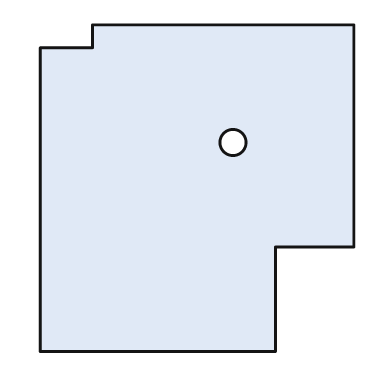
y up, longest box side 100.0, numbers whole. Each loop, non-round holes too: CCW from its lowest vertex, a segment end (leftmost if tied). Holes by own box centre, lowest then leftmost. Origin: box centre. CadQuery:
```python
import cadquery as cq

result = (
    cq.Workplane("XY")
    .moveTo(-48.0, -50.0)
    .lineTo(24.0, -50.0)
    .lineTo(24.0, -18.0)
    .lineTo(48.0, -18.0)
    .lineTo(48.0, 50.0)
    .lineTo(-32.0, 50.0)
    .lineTo(-32.0, 43.0)
    .lineTo(-48.0, 43.0)
    .close()
    .moveTo(11.0, 14.0)
    .circle(4.0)
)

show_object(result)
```